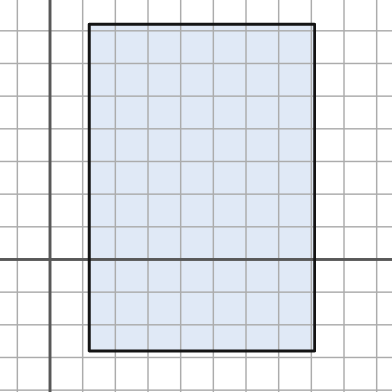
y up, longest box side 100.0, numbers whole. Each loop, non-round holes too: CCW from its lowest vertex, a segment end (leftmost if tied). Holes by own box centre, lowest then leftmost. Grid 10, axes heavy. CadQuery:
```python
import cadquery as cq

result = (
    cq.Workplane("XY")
    .moveTo(12.0, -28.0)
    .lineTo(81.0, -28.0)
    .lineTo(81.0, 72.0)
    .lineTo(12.0, 72.0)
    .close()
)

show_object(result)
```